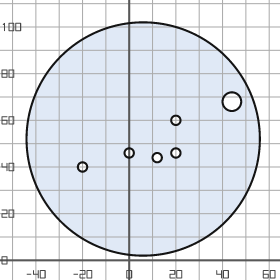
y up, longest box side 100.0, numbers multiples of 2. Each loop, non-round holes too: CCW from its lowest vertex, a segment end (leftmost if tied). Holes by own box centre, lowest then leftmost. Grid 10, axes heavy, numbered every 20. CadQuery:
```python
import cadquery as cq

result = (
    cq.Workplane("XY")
    .moveTo(6.0, 52.0)
    .circle(50.0)
    .moveTo(-20.0, 40.0)
    .circle(2.0)
    .moveTo(12.0, 44.0)
    .circle(2.0)
    .moveTo(0.0, 46.0)
    .circle(2.0)
    .moveTo(20.0, 46.0)
    .circle(2.0)
    .moveTo(20.0, 60.0)
    .circle(2.0)
    .moveTo(44.0, 68.0)
    .circle(4.0)
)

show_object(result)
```